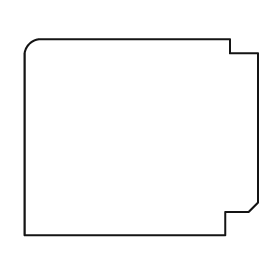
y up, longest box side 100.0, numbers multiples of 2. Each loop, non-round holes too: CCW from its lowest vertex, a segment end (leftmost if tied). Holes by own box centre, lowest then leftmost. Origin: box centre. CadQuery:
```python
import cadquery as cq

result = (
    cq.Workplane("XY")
    .moveTo(-50.0, -42.0)
    .lineTo(36.0, -42.0)
    .lineTo(36.0, -32.0)
    .lineTo(46.0, -32.0)
    .lineTo(50.0, -28.0)
    .lineTo(50.0, 36.0)
    .lineTo(38.0, 36.0)
    .lineTo(38.0, 42.0)
    .lineTo(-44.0, 42.0)
    .threePointArc((-48.0, 40.0), (-50.0, 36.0))
    .close()
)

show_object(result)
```